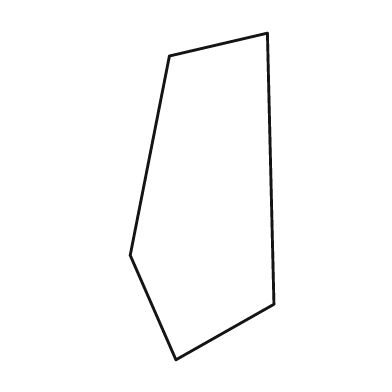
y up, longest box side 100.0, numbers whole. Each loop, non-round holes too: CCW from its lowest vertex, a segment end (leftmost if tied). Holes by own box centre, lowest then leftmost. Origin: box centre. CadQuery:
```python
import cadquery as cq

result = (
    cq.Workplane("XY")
    .moveTo(-8.0, -50.0)
    .lineTo(22.0, -33.0)
    .lineTo(20.0, 50.0)
    .lineTo(-10.0, 43.0)
    .lineTo(-22.0, -18.0)
    .close()
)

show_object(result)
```